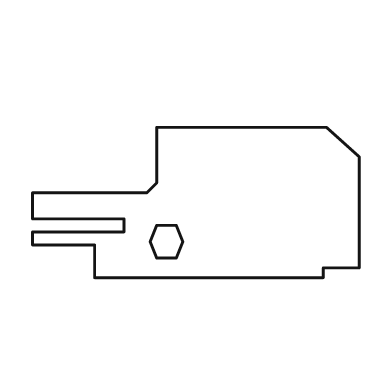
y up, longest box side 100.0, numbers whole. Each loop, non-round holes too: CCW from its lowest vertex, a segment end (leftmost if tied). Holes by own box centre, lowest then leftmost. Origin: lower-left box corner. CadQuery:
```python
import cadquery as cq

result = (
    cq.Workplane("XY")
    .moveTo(19.0, 0.0)
    .lineTo(89.0, 0.0)
    .lineTo(89.0, 3.0)
    .lineTo(100.0, 3.0)
    .lineTo(100.0, 37.0)
    .lineTo(90.0, 46.0)
    .lineTo(38.0, 46.0)
    .lineTo(38.0, 29.0)
    .lineTo(35.0, 26.0)
    .lineTo(0.0, 26.0)
    .lineTo(0.0, 18.0)
    .lineTo(28.0, 18.0)
    .lineTo(28.0, 14.0)
    .lineTo(0.0, 14.0)
    .lineTo(0.0, 10.0)
    .lineTo(19.0, 10.0)
    .close()
    .moveTo(38.0, 6.0)
    .lineTo(44.0, 6.0)
    .lineTo(46.0, 11.0)
    .lineTo(44.0, 16.0)
    .lineTo(38.0, 16.0)
    .lineTo(36.0, 11.0)
    .close()
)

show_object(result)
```